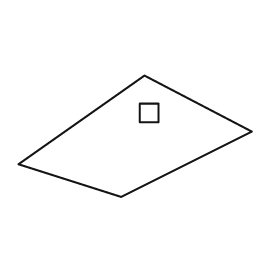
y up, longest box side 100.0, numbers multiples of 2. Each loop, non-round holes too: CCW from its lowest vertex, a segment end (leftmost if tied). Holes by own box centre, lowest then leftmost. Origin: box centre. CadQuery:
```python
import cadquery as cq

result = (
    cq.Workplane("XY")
    .moveTo(-6.0, -26.0)
    .lineTo(50.0, 2.0)
    .lineTo(4.0, 26.0)
    .lineTo(-50.0, -12.0)
    .close()
    .moveTo(2.0, 6.0)
    .lineTo(10.0, 6.0)
    .lineTo(10.0, 14.0)
    .lineTo(2.0, 14.0)
    .close()
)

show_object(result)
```